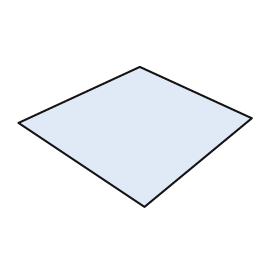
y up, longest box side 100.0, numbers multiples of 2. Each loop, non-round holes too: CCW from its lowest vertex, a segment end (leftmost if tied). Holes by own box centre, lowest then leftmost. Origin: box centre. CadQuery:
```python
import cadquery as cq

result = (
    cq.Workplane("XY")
    .moveTo(4.0, -30.0)
    .lineTo(50.0, 8.0)
    .lineTo(2.0, 30.0)
    .lineTo(-50.0, 6.0)
    .close()
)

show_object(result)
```